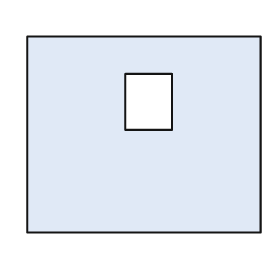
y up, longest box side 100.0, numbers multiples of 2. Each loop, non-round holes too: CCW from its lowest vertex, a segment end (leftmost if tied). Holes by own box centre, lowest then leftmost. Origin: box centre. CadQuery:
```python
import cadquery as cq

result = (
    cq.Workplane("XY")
    .moveTo(-50.0, -42.0)
    .lineTo(50.0, -42.0)
    .lineTo(50.0, 42.0)
    .lineTo(-50.0, 42.0)
    .close()
    .moveTo(-8.0, 2.0)
    .lineTo(12.0, 2.0)
    .lineTo(12.0, 26.0)
    .lineTo(-8.0, 26.0)
    .close()
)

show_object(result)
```